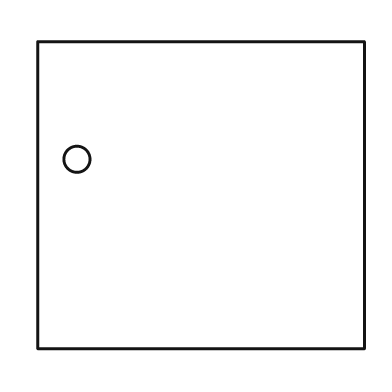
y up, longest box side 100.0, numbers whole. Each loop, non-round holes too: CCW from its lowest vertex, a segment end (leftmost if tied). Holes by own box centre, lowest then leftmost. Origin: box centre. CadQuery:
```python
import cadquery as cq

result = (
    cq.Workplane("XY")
    .moveTo(-50.0, -47.0)
    .lineTo(50.0, -47.0)
    .lineTo(50.0, 47.0)
    .lineTo(-50.0, 47.0)
    .close()
    .moveTo(-38.0, 11.0)
    .circle(4.0)
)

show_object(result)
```